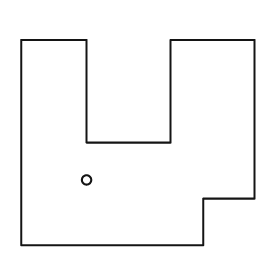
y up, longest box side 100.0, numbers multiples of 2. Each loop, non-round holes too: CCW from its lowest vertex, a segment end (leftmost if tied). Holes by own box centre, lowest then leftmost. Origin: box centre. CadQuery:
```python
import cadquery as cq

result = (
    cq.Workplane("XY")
    .moveTo(-50.0, -44.0)
    .lineTo(28.0, -44.0)
    .lineTo(28.0, -24.0)
    .lineTo(50.0, -24.0)
    .lineTo(50.0, 44.0)
    .lineTo(14.0, 44.0)
    .lineTo(14.0, 0.0)
    .lineTo(-22.0, 0.0)
    .lineTo(-22.0, 44.0)
    .lineTo(-50.0, 44.0)
    .close()
    .moveTo(-22.0, -16.0)
    .circle(2.0)
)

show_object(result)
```